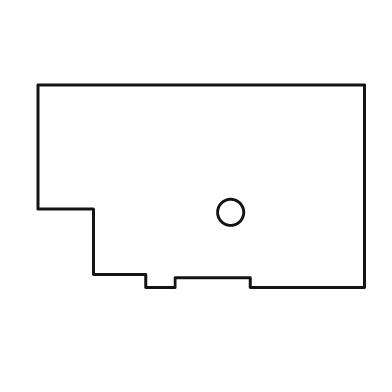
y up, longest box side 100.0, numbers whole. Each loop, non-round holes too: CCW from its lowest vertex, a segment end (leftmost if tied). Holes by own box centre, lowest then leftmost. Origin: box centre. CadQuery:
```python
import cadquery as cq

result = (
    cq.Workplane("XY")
    .moveTo(-17.0, -31.0)
    .lineTo(-8.0, -31.0)
    .lineTo(-8.0, -28.0)
    .lineTo(15.0, -28.0)
    .lineTo(15.0, -31.0)
    .lineTo(50.0, -31.0)
    .lineTo(50.0, 31.0)
    .lineTo(-50.0, 31.0)
    .lineTo(-50.0, -7.0)
    .lineTo(-33.0, -7.0)
    .lineTo(-33.0, -27.0)
    .lineTo(-17.0, -27.0)
    .close()
    .moveTo(9.0, -8.0)
    .circle(4.0)
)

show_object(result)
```